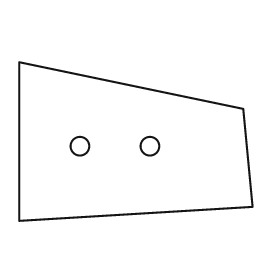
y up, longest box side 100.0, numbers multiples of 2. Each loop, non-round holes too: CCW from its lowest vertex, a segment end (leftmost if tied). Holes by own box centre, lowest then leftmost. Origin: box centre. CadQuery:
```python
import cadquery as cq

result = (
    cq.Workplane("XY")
    .moveTo(-50.0, -34.0)
    .lineTo(50.0, -28.0)
    .lineTo(46.0, 14.0)
    .lineTo(-50.0, 34.0)
    .close()
    .moveTo(-24.0, -2.0)
    .circle(4.0)
    .moveTo(6.0, -2.0)
    .circle(4.0)
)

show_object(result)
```